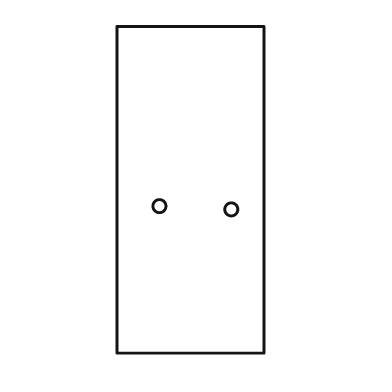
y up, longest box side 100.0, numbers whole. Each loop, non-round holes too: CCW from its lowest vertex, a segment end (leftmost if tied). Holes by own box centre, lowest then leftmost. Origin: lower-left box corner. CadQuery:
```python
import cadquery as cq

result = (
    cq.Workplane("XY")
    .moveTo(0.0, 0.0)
    .lineTo(45.0, 0.0)
    .lineTo(45.0, 100.0)
    .lineTo(0.0, 100.0)
    .close()
    .moveTo(35.0, 44.0)
    .circle(2.0)
    .moveTo(13.0, 45.0)
    .circle(2.0)
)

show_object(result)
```